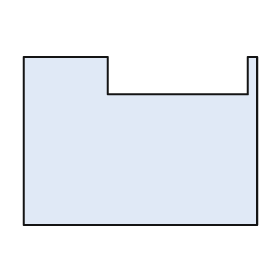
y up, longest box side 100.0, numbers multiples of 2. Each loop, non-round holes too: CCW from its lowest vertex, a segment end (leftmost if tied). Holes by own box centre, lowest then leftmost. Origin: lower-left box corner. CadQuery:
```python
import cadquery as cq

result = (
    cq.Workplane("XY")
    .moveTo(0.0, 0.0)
    .lineTo(100.0, 0.0)
    .lineTo(100.0, 72.0)
    .lineTo(96.0, 72.0)
    .lineTo(96.0, 56.0)
    .lineTo(36.0, 56.0)
    .lineTo(36.0, 72.0)
    .lineTo(0.0, 72.0)
    .close()
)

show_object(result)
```